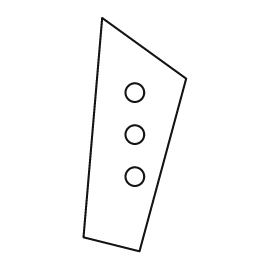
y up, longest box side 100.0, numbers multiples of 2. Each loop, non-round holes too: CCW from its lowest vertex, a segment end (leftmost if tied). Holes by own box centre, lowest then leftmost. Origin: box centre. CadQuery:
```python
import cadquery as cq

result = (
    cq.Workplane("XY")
    .moveTo(2.0, -50.0)
    .lineTo(22.0, 24.0)
    .lineTo(-14.0, 50.0)
    .lineTo(-22.0, -44.0)
    .close()
    .moveTo(0.0, -18.0)
    .circle(4.0)
    .moveTo(0.0, 0.0)
    .circle(4.0)
    .moveTo(0.0, 18.0)
    .circle(4.0)
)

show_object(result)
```